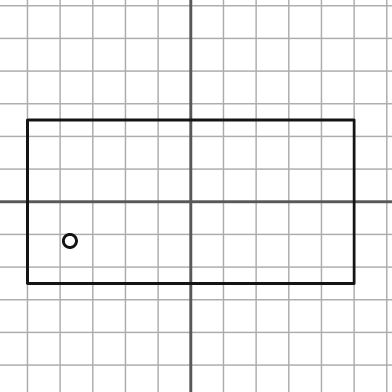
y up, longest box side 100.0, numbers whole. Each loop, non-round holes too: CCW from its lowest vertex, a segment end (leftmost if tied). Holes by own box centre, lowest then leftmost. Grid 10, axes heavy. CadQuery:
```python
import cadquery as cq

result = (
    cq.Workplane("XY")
    .moveTo(-50.0, -25.0)
    .lineTo(50.0, -25.0)
    .lineTo(50.0, 25.0)
    .lineTo(-50.0, 25.0)
    .close()
    .moveTo(-37.0, -12.0)
    .circle(2.0)
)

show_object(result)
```